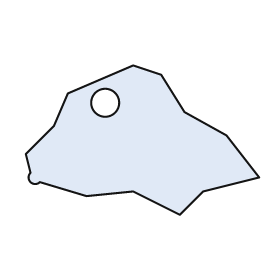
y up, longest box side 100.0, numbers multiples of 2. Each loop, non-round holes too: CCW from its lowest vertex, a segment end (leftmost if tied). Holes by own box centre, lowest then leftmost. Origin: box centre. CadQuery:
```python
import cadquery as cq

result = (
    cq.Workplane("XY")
    .moveTo(16.0, -32.0)
    .lineTo(26.0, -22.0)
    .lineTo(50.0, -16.0)
    .lineTo(36.0, 2.0)
    .lineTo(18.0, 12.0)
    .lineTo(8.0, 28.0)
    .lineTo(-4.0, 32.0)
    .lineTo(-32.0, 20.0)
    .lineTo(-38.0, 6.0)
    .lineTo(-50.0, -6.0)
    .lineTo(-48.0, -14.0)
    .threePointArc((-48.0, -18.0), (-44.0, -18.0))
    .lineTo(-24.0, -24.0)
    .lineTo(-4.0, -22.0)
    .close()
    .moveTo(-16.0, 16.0)
    .circle(6.0)
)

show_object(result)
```